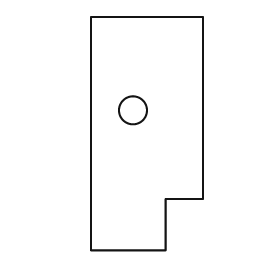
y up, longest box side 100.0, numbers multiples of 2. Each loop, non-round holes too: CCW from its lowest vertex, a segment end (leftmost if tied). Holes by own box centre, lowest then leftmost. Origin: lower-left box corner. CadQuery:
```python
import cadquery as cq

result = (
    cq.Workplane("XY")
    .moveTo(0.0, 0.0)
    .lineTo(32.0, 0.0)
    .lineTo(32.0, 22.0)
    .lineTo(48.0, 22.0)
    .lineTo(48.0, 100.0)
    .lineTo(0.0, 100.0)
    .close()
    .moveTo(18.0, 60.0)
    .circle(6.0)
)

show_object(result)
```